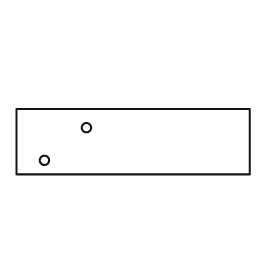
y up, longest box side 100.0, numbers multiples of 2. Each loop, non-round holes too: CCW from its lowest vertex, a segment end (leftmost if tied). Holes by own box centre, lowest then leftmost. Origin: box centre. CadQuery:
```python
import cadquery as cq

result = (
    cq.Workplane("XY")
    .moveTo(-50.0, -14.0)
    .lineTo(50.0, -14.0)
    .lineTo(50.0, 14.0)
    .lineTo(-50.0, 14.0)
    .close()
    .moveTo(-38.0, -8.0)
    .circle(2.0)
    .moveTo(-20.0, 6.0)
    .circle(2.0)
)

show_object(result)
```